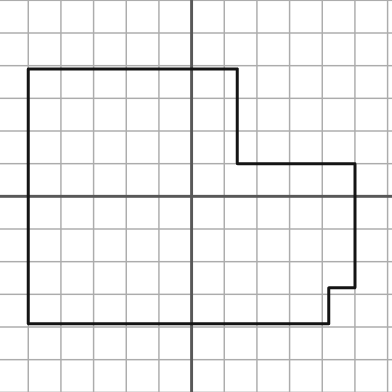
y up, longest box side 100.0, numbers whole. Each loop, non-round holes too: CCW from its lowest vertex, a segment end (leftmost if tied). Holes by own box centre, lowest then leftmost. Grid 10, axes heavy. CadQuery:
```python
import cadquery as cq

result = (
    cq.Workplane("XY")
    .moveTo(-50.0, -39.0)
    .lineTo(42.0, -39.0)
    .lineTo(42.0, -28.0)
    .lineTo(50.0, -28.0)
    .lineTo(50.0, 10.0)
    .lineTo(14.0, 10.0)
    .lineTo(14.0, 39.0)
    .lineTo(-50.0, 39.0)
    .close()
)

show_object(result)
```